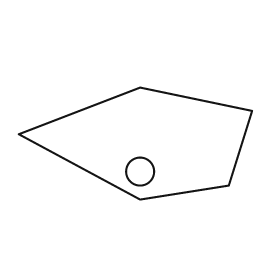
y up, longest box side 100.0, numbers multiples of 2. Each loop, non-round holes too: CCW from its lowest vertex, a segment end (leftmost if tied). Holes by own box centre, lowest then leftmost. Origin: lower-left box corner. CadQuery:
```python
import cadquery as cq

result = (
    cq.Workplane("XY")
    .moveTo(52.0, 0.0)
    .lineTo(90.0, 6.0)
    .lineTo(100.0, 38.0)
    .lineTo(52.0, 48.0)
    .lineTo(0.0, 28.0)
    .close()
    .moveTo(52.0, 12.0)
    .circle(6.0)
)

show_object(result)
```